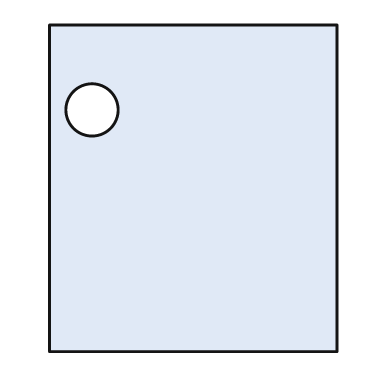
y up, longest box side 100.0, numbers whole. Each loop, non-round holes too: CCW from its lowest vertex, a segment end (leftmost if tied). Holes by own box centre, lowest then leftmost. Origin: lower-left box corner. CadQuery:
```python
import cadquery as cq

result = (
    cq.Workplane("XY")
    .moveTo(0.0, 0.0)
    .lineTo(88.0, 0.0)
    .lineTo(88.0, 100.0)
    .lineTo(0.0, 100.0)
    .close()
    .moveTo(13.0, 74.0)
    .circle(8.0)
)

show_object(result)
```